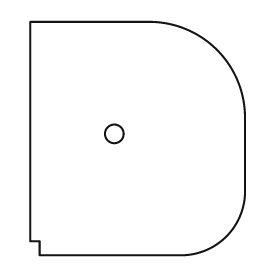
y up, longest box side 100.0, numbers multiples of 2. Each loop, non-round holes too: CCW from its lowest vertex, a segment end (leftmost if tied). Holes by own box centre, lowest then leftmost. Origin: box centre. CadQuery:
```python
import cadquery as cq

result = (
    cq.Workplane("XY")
    .moveTo(-42.0, -50.0)
    .lineTo(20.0, -50.0)
    .threePointArc((38.0, -42.0), (46.0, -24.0))
    .lineTo(46.0, 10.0)
    .threePointArc((34.0, 38.0), (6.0, 50.0))
    .lineTo(-46.0, 50.0)
    .lineTo(-46.0, -44.0)
    .lineTo(-42.0, -44.0)
    .close()
    .moveTo(-10.0, 2.0)
    .circle(4.0)
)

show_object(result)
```